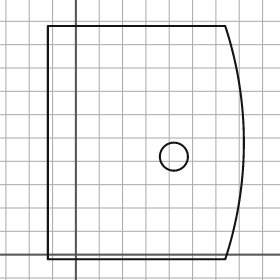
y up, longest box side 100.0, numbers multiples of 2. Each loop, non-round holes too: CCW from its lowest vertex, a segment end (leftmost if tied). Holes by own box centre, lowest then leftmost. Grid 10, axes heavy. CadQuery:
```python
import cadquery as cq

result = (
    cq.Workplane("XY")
    .moveTo(-12.0, -2.0)
    .lineTo(64.0, -2.0)
    .threePointArc((72.0, 48.0), (64.0, 98.0))
    .lineTo(-12.0, 98.0)
    .close()
    .moveTo(42.0, 42.0)
    .circle(6.0)
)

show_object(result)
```